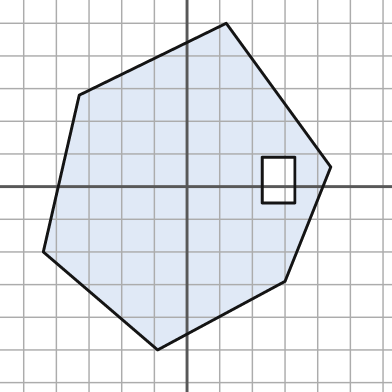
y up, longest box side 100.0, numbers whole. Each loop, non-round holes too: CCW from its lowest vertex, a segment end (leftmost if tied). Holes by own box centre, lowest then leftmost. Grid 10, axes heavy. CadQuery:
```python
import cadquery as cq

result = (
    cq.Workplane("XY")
    .moveTo(-9.0, -50.0)
    .lineTo(30.0, -29.0)
    .lineTo(44.0, 6.0)
    .lineTo(12.0, 50.0)
    .lineTo(-33.0, 28.0)
    .lineTo(-44.0, -20.0)
    .close()
    .moveTo(23.0, -5.0)
    .lineTo(33.0, -5.0)
    .lineTo(33.0, 9.0)
    .lineTo(23.0, 9.0)
    .close()
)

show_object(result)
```